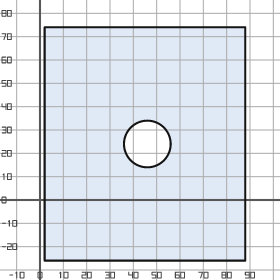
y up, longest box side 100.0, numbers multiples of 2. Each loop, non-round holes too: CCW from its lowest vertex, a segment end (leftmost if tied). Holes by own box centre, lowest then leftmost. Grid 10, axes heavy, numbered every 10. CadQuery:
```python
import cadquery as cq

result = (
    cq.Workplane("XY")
    .moveTo(2.0, -26.0)
    .lineTo(88.0, -26.0)
    .lineTo(88.0, 74.0)
    .lineTo(2.0, 74.0)
    .close()
    .moveTo(46.0, 24.0)
    .circle(10.0)
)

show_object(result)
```